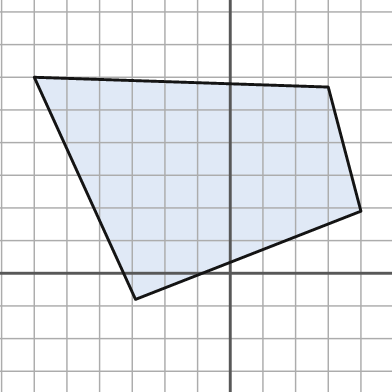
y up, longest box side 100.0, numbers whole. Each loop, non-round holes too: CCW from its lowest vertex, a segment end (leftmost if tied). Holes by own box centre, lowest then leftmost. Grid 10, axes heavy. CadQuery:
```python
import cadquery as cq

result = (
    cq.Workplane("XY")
    .moveTo(-29.0, -8.0)
    .lineTo(40.0, 19.0)
    .lineTo(30.0, 57.0)
    .lineTo(-60.0, 60.0)
    .close()
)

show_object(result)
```